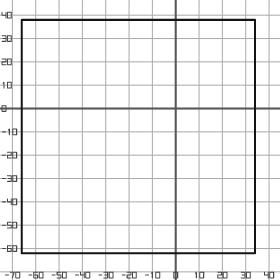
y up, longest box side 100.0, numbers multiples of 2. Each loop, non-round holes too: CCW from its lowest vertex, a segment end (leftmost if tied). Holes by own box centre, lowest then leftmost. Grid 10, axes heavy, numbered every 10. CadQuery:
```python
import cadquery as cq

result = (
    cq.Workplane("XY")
    .moveTo(-66.0, -62.0)
    .lineTo(34.0, -62.0)
    .lineTo(34.0, 38.0)
    .lineTo(-66.0, 38.0)
    .close()
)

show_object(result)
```